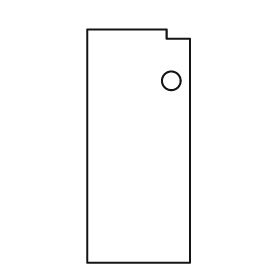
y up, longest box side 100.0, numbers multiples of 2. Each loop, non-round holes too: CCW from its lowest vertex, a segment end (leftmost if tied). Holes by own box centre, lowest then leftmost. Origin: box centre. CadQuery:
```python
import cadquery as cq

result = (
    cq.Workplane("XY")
    .moveTo(-22.0, -50.0)
    .lineTo(22.0, -50.0)
    .lineTo(22.0, 46.0)
    .lineTo(12.0, 46.0)
    .lineTo(12.0, 50.0)
    .lineTo(-22.0, 50.0)
    .close()
    .moveTo(14.0, 28.0)
    .circle(4.0)
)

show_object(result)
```